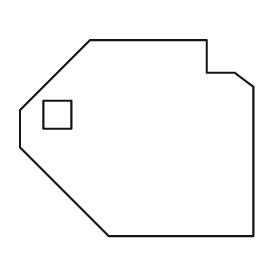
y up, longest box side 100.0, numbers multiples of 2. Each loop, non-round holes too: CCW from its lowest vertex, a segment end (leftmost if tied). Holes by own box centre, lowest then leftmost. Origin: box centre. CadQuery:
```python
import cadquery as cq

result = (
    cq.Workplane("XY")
    .moveTo(-12.0, -42.0)
    .lineTo(50.0, -42.0)
    .lineTo(50.0, 22.0)
    .lineTo(42.0, 28.0)
    .lineTo(30.0, 28.0)
    .lineTo(30.0, 42.0)
    .lineTo(-20.0, 42.0)
    .lineTo(-50.0, 12.0)
    .lineTo(-50.0, -4.0)
    .close()
    .moveTo(-40.0, 4.0)
    .lineTo(-28.0, 4.0)
    .lineTo(-28.0, 16.0)
    .lineTo(-40.0, 16.0)
    .close()
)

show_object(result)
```